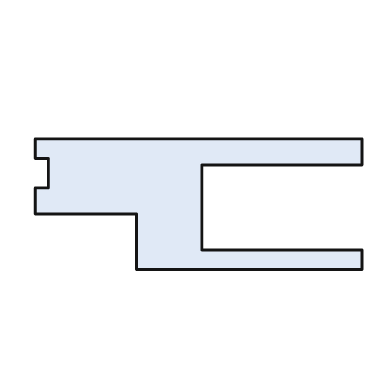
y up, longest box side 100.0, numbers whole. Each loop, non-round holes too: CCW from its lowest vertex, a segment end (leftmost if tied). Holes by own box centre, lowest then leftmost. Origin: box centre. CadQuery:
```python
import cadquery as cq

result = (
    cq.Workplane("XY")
    .moveTo(-19.0, -20.0)
    .lineTo(50.0, -20.0)
    .lineTo(50.0, -14.0)
    .lineTo(1.0, -14.0)
    .lineTo(1.0, 12.0)
    .lineTo(50.0, 12.0)
    .lineTo(50.0, 20.0)
    .lineTo(-50.0, 20.0)
    .lineTo(-50.0, 14.0)
    .lineTo(-46.0, 14.0)
    .lineTo(-46.0, 5.0)
    .lineTo(-50.0, 5.0)
    .lineTo(-50.0, -3.0)
    .lineTo(-19.0, -3.0)
    .close()
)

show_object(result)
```